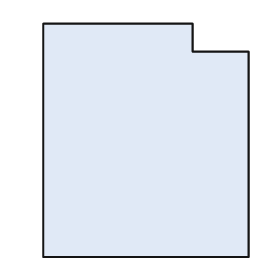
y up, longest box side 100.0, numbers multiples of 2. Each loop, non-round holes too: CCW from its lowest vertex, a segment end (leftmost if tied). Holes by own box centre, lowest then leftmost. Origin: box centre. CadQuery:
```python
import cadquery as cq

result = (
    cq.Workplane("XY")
    .moveTo(-44.0, -50.0)
    .lineTo(44.0, -50.0)
    .lineTo(44.0, 38.0)
    .lineTo(20.0, 38.0)
    .lineTo(20.0, 50.0)
    .lineTo(-44.0, 50.0)
    .close()
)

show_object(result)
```